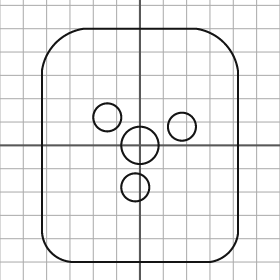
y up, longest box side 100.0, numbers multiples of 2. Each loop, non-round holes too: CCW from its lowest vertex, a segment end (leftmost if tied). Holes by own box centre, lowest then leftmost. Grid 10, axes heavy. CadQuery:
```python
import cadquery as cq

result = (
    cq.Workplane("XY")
    .moveTo(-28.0, -50.0)
    .lineTo(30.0, -50.0)
    .threePointArc((38.0, -46.0), (42.0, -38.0))
    .lineTo(42.0, 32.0)
    .threePointArc((36.0, 44.0), (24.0, 50.0))
    .lineTo(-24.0, 50.0)
    .threePointArc((-36.0, 44.0), (-42.0, 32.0))
    .lineTo(-42.0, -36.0)
    .threePointArc((-38.0, -46.0), (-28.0, -50.0))
    .close()
    .moveTo(-2.0, -18.0)
    .circle(6.0)
    .moveTo(0.0, 0.0)
    .circle(8.0)
    .moveTo(18.0, 8.0)
    .circle(6.0)
    .moveTo(-14.0, 12.0)
    .circle(6.0)
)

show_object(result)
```